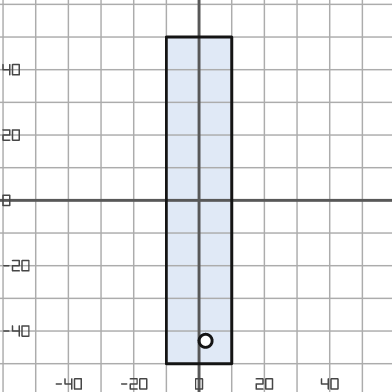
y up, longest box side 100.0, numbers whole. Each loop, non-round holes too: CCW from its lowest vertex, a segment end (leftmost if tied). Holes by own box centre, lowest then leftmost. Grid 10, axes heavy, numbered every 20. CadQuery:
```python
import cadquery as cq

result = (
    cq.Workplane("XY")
    .moveTo(-10.0, -50.0)
    .lineTo(10.0, -50.0)
    .lineTo(10.0, 50.0)
    .lineTo(-10.0, 50.0)
    .close()
    .moveTo(2.0, -43.0)
    .circle(2.0)
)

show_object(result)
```